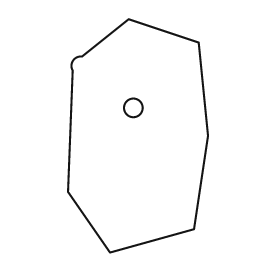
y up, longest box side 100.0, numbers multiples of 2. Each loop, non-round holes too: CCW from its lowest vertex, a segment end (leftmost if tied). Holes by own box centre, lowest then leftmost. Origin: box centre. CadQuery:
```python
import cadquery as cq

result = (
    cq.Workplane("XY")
    .moveTo(-12.0, -50.0)
    .lineTo(24.0, -40.0)
    .lineTo(30.0, 0.0)
    .lineTo(26.0, 40.0)
    .lineTo(-4.0, 50.0)
    .lineTo(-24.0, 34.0)
    .threePointArc((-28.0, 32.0), (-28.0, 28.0))
    .lineTo(-30.0, -24.0)
    .close()
    .moveTo(-2.0, 12.0)
    .circle(4.0)
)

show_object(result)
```